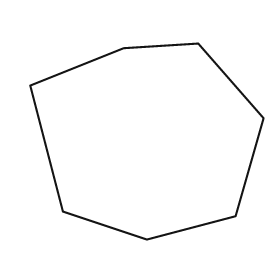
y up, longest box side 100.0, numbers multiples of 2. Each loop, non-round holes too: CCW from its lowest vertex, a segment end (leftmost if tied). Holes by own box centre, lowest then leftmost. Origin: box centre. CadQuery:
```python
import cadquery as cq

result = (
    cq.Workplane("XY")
    .moveTo(0.0, -42.0)
    .lineTo(38.0, -32.0)
    .lineTo(50.0, 10.0)
    .lineTo(22.0, 42.0)
    .lineTo(-10.0, 40.0)
    .lineTo(-50.0, 24.0)
    .lineTo(-36.0, -30.0)
    .close()
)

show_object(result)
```